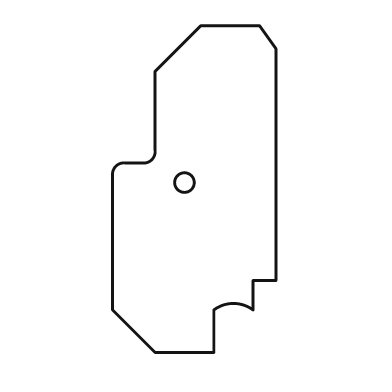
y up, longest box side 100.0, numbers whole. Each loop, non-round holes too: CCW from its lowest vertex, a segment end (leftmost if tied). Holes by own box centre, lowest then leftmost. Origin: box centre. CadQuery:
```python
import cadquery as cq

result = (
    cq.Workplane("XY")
    .moveTo(-12.0, -50.0)
    .lineTo(6.0, -50.0)
    .lineTo(6.0, -37.0)
    .threePointArc((12.0, -35.0), (18.0, -37.0))
    .lineTo(18.0, -28.0)
    .lineTo(25.0, -28.0)
    .lineTo(25.0, 43.0)
    .lineTo(20.0, 50.0)
    .lineTo(2.0, 50.0)
    .lineTo(-12.0, 36.0)
    .lineTo(-12.0, 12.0)
    .threePointArc((-13.0, 9.0), (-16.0, 8.0))
    .lineTo(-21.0, 8.0)
    .threePointArc((-24.0, 7.0), (-25.0, 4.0))
    .lineTo(-25.0, -37.0)
    .close()
    .moveTo(-3.0, 2.0)
    .circle(3.0)
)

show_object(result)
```